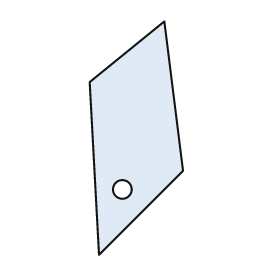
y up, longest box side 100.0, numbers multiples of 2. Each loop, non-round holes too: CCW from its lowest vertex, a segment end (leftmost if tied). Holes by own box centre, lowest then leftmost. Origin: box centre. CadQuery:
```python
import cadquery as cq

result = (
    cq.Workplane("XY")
    .moveTo(-16.0, -50.0)
    .lineTo(20.0, -14.0)
    .lineTo(12.0, 50.0)
    .lineTo(-20.0, 24.0)
    .close()
    .moveTo(-6.0, -22.0)
    .circle(4.0)
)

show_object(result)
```